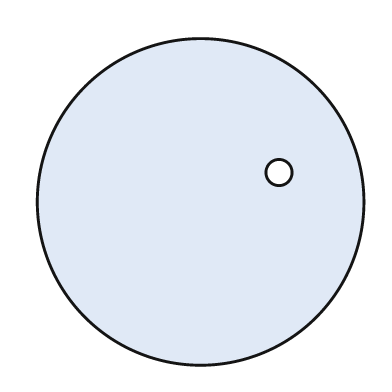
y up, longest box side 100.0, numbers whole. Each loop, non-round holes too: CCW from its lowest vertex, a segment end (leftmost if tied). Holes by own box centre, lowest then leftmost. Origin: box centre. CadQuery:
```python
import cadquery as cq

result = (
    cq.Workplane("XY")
    .moveTo(0.0, 0.0)
    .circle(50.0)
    .moveTo(24.0, 9.0)
    .circle(4.0)
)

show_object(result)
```